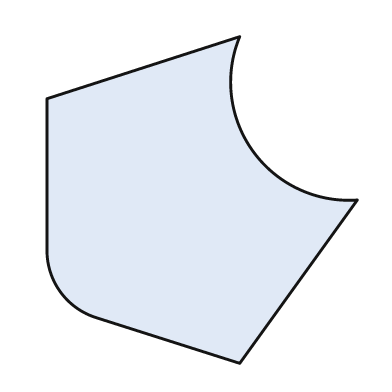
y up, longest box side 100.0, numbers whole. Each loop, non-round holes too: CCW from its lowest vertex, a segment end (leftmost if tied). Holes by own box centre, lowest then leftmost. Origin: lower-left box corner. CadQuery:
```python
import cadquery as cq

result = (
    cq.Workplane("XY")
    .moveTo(59.0, 0.0)
    .lineTo(95.0, 50.0)
    .threePointArc((63.0, 65.0), (59.0, 100.0))
    .lineTo(0.0, 81.0)
    .lineTo(0.0, 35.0)
    .threePointArc((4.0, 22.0), (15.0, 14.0))
    .close()
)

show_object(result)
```